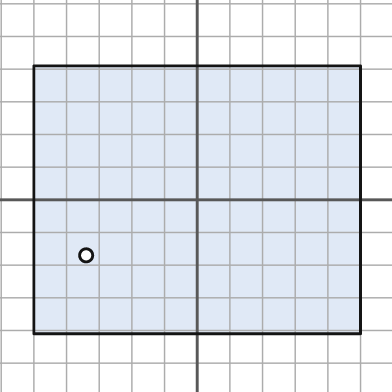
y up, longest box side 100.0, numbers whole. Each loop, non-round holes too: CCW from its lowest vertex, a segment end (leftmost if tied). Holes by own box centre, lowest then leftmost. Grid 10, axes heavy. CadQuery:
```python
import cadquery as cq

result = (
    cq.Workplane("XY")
    .moveTo(-50.0, -41.0)
    .lineTo(50.0, -41.0)
    .lineTo(50.0, 41.0)
    .lineTo(-50.0, 41.0)
    .close()
    .moveTo(-34.0, -17.0)
    .circle(2.0)
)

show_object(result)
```